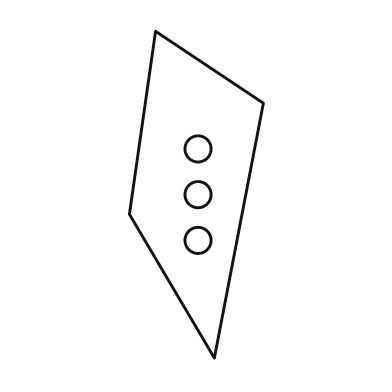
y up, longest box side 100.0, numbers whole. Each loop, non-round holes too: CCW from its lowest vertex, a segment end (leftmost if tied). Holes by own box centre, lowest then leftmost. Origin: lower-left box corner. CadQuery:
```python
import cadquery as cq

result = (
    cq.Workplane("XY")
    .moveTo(26.0, 0.0)
    .lineTo(41.0, 78.0)
    .lineTo(8.0, 100.0)
    .lineTo(0.0, 44.0)
    .close()
    .moveTo(21.0, 36.0)
    .circle(4.0)
    .moveTo(21.0, 50.0)
    .circle(4.0)
    .moveTo(21.0, 64.0)
    .circle(4.0)
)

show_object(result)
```